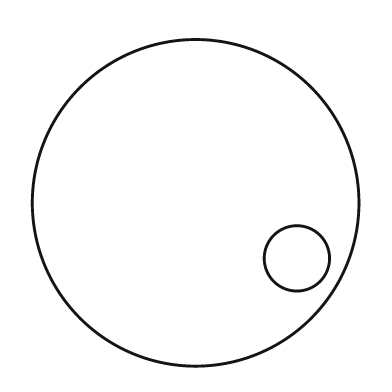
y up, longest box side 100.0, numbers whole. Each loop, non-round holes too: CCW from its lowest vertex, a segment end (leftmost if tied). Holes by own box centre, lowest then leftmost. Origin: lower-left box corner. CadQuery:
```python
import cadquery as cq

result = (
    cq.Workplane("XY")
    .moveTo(50.0, 50.0)
    .circle(50.0)
    .moveTo(81.0, 33.0)
    .circle(10.0)
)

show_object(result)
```